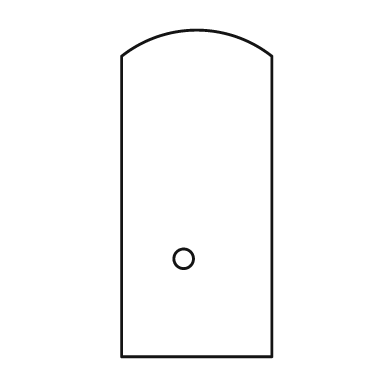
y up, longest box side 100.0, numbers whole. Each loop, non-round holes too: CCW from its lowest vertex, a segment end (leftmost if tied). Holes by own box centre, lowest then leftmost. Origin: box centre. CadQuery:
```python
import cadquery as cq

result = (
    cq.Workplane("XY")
    .moveTo(-23.0, -50.0)
    .lineTo(23.0, -50.0)
    .lineTo(23.0, 42.0)
    .threePointArc((0.0, 50.0), (-23.0, 42.0))
    .close()
    .moveTo(-4.0, -20.0)
    .circle(3.0)
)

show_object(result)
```